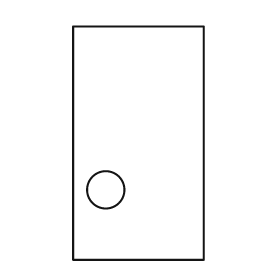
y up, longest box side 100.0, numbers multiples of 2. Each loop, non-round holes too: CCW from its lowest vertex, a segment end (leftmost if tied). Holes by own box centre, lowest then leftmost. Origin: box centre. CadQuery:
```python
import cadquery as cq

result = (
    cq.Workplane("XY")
    .moveTo(-28.0, -50.0)
    .lineTo(28.0, -50.0)
    .lineTo(28.0, 50.0)
    .lineTo(-28.0, 50.0)
    .close()
    .moveTo(-14.0, -20.0)
    .circle(8.0)
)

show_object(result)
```